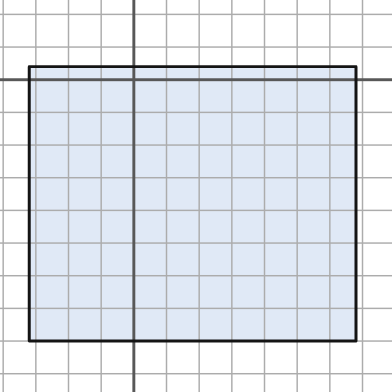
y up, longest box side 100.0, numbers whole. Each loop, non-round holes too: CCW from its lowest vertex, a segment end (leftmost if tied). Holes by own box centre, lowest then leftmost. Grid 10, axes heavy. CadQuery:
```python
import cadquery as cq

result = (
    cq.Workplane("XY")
    .moveTo(-32.0, -80.0)
    .lineTo(68.0, -80.0)
    .lineTo(68.0, 4.0)
    .lineTo(-32.0, 4.0)
    .close()
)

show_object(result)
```